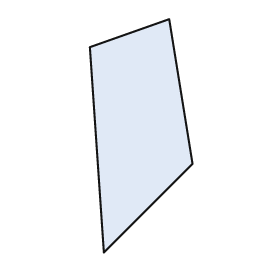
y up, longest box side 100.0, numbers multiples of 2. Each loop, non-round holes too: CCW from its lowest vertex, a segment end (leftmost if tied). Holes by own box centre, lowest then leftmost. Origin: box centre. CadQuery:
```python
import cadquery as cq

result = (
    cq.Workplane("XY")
    .moveTo(-16.0, -50.0)
    .lineTo(22.0, -12.0)
    .lineTo(12.0, 50.0)
    .lineTo(-22.0, 38.0)
    .close()
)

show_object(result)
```